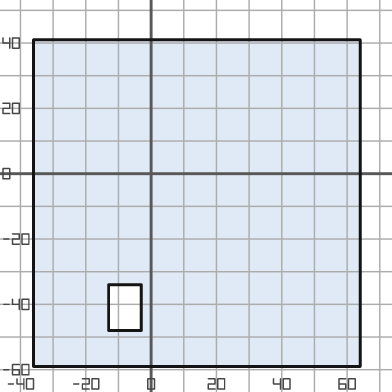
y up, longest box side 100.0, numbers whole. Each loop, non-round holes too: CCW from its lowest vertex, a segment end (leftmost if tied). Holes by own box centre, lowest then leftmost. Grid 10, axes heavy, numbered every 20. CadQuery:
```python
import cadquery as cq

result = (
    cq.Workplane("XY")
    .moveTo(-36.0, -59.0)
    .lineTo(64.0, -59.0)
    .lineTo(64.0, 41.0)
    .lineTo(-36.0, 41.0)
    .close()
    .moveTo(-13.0, -48.0)
    .lineTo(-3.0, -48.0)
    .lineTo(-3.0, -34.0)
    .lineTo(-13.0, -34.0)
    .close()
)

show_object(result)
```